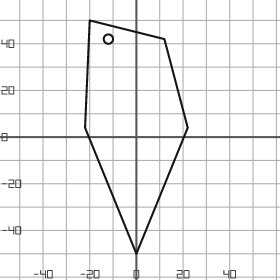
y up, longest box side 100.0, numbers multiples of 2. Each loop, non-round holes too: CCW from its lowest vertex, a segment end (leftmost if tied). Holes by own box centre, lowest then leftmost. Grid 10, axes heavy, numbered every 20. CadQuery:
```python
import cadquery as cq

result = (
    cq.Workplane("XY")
    .moveTo(0.0, -50.0)
    .lineTo(22.0, 4.0)
    .lineTo(12.0, 42.0)
    .lineTo(-20.0, 50.0)
    .lineTo(-22.0, 4.0)
    .close()
    .moveTo(-12.0, 42.0)
    .circle(2.0)
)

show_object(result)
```